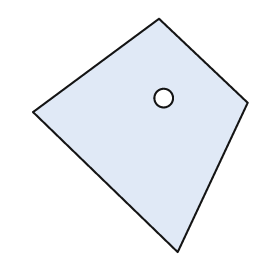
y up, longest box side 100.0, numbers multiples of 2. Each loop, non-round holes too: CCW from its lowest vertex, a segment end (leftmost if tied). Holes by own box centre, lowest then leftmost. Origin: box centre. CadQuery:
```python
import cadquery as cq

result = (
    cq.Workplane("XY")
    .moveTo(16.0, -50.0)
    .lineTo(46.0, 14.0)
    .lineTo(8.0, 50.0)
    .lineTo(-46.0, 10.0)
    .close()
    .moveTo(10.0, 16.0)
    .circle(4.0)
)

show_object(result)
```